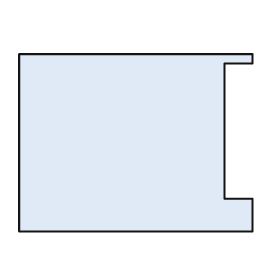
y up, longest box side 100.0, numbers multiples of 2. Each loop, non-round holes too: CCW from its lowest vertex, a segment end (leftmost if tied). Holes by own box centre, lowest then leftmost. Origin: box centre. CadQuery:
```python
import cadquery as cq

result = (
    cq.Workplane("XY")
    .moveTo(-50.0, -38.0)
    .lineTo(50.0, -38.0)
    .lineTo(50.0, -24.0)
    .lineTo(38.0, -24.0)
    .lineTo(38.0, 34.0)
    .lineTo(50.0, 34.0)
    .lineTo(50.0, 38.0)
    .lineTo(-50.0, 38.0)
    .close()
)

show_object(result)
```